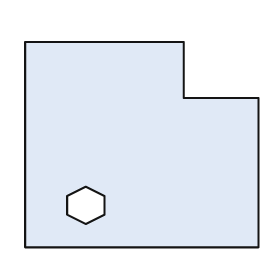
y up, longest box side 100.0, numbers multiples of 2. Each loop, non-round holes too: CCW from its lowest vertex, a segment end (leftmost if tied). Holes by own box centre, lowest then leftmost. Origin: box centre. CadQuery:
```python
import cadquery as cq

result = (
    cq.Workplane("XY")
    .moveTo(-50.0, -44.0)
    .lineTo(50.0, -44.0)
    .lineTo(50.0, 20.0)
    .lineTo(18.0, 20.0)
    .lineTo(18.0, 44.0)
    .lineTo(-50.0, 44.0)
    .close()
    .moveTo(-24.0, -34.0)
    .lineTo(-16.0, -30.0)
    .lineTo(-16.0, -22.0)
    .lineTo(-24.0, -18.0)
    .lineTo(-32.0, -22.0)
    .lineTo(-32.0, -30.0)
    .close()
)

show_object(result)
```